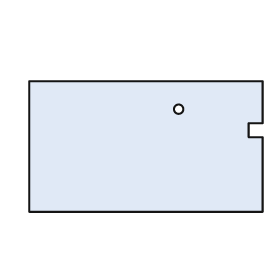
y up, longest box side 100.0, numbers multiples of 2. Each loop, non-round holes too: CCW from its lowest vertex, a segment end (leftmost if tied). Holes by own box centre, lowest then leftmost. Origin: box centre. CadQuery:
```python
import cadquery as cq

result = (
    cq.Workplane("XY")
    .moveTo(-50.0, -28.0)
    .lineTo(50.0, -28.0)
    .lineTo(50.0, 4.0)
    .lineTo(44.0, 4.0)
    .lineTo(44.0, 10.0)
    .lineTo(50.0, 10.0)
    .lineTo(50.0, 28.0)
    .lineTo(-50.0, 28.0)
    .close()
    .moveTo(14.0, 16.0)
    .circle(2.0)
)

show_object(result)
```